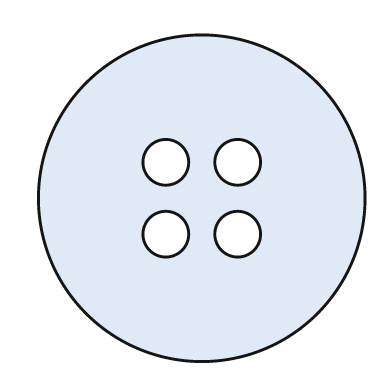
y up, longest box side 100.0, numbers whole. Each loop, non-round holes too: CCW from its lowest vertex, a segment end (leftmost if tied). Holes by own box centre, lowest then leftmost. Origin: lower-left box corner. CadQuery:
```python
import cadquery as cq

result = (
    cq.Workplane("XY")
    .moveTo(50.0, 50.0)
    .circle(50.0)
    .moveTo(39.0, 39.0)
    .circle(7.0)
    .moveTo(61.0, 39.0)
    .circle(7.0)
    .moveTo(39.0, 61.0)
    .circle(7.0)
    .moveTo(61.0, 61.0)
    .circle(7.0)
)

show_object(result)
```